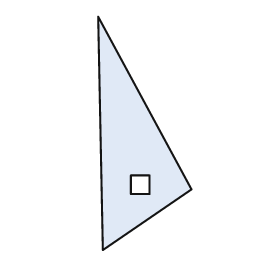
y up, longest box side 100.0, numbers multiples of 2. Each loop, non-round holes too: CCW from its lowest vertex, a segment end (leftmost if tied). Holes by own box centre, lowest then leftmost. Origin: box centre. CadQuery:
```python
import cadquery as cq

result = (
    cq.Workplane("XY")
    .moveTo(-18.0, -50.0)
    .lineTo(20.0, -24.0)
    .lineTo(-20.0, 50.0)
    .close()
    .moveTo(-6.0, -26.0)
    .lineTo(2.0, -26.0)
    .lineTo(2.0, -18.0)
    .lineTo(-6.0, -18.0)
    .close()
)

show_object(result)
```